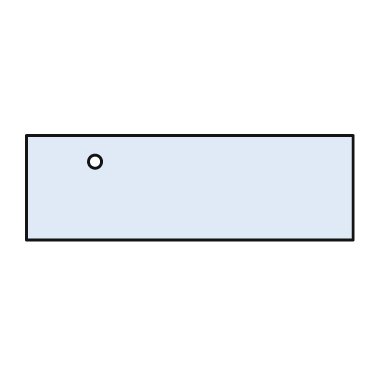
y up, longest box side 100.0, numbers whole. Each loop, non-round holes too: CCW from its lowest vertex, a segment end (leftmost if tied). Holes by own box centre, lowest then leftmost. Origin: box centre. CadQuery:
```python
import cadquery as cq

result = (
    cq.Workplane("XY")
    .moveTo(-50.0, -16.0)
    .lineTo(50.0, -16.0)
    .lineTo(50.0, 16.0)
    .lineTo(-50.0, 16.0)
    .close()
    .moveTo(-29.0, 8.0)
    .circle(2.0)
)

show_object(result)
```